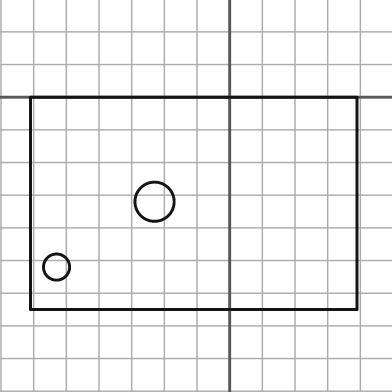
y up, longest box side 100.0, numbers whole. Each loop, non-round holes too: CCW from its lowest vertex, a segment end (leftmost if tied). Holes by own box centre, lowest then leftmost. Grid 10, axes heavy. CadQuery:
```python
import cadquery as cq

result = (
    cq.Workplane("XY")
    .moveTo(-61.0, -65.0)
    .lineTo(39.0, -65.0)
    .lineTo(39.0, 0.0)
    .lineTo(-61.0, 0.0)
    .close()
    .moveTo(-53.0, -52.0)
    .circle(4.0)
    .moveTo(-23.0, -32.0)
    .circle(6.0)
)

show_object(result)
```